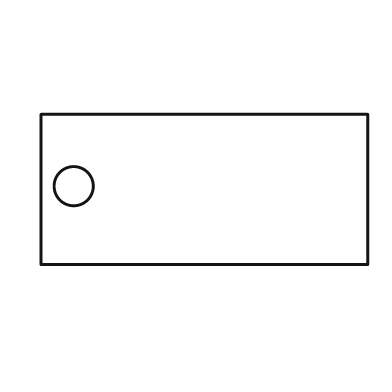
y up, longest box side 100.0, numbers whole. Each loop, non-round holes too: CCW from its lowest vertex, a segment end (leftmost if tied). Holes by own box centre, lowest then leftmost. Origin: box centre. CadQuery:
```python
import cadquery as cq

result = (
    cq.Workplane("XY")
    .moveTo(-50.0, -23.0)
    .lineTo(50.0, -23.0)
    .lineTo(50.0, 23.0)
    .lineTo(-50.0, 23.0)
    .close()
    .moveTo(-40.0, 1.0)
    .circle(6.0)
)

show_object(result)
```